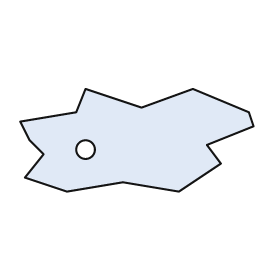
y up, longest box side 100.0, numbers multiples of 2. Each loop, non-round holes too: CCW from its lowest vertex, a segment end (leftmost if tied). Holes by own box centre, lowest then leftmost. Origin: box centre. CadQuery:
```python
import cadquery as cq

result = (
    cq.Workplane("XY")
    .moveTo(-30.0, -22.0)
    .lineTo(-6.0, -18.0)
    .lineTo(18.0, -22.0)
    .lineTo(36.0, -10.0)
    .lineTo(30.0, -2.0)
    .lineTo(50.0, 6.0)
    .lineTo(48.0, 12.0)
    .lineTo(24.0, 22.0)
    .lineTo(2.0, 14.0)
    .lineTo(-22.0, 22.0)
    .lineTo(-26.0, 12.0)
    .lineTo(-50.0, 8.0)
    .lineTo(-46.0, 0.0)
    .lineTo(-40.0, -6.0)
    .lineTo(-48.0, -16.0)
    .close()
    .moveTo(-22.0, -4.0)
    .circle(4.0)
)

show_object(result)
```